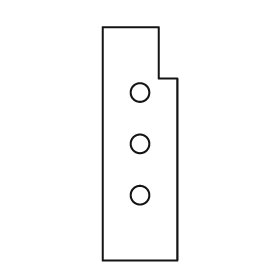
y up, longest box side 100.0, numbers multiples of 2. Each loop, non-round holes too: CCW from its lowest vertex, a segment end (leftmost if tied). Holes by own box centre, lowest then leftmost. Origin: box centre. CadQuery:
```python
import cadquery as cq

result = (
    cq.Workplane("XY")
    .moveTo(-16.0, -50.0)
    .lineTo(16.0, -50.0)
    .lineTo(16.0, 28.0)
    .lineTo(8.0, 28.0)
    .lineTo(8.0, 50.0)
    .lineTo(-16.0, 50.0)
    .close()
    .moveTo(0.0, -22.0)
    .circle(4.0)
    .moveTo(0.0, 0.0)
    .circle(4.0)
    .moveTo(0.0, 22.0)
    .circle(4.0)
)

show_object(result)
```